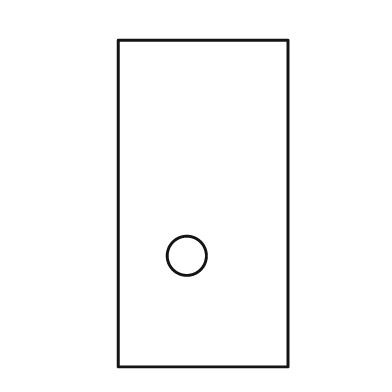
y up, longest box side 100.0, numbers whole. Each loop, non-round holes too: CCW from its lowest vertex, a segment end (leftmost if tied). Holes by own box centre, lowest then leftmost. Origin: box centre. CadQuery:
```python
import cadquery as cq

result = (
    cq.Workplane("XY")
    .moveTo(-26.0, -50.0)
    .lineTo(26.0, -50.0)
    .lineTo(26.0, 50.0)
    .lineTo(-26.0, 50.0)
    .close()
    .moveTo(-5.0, -16.0)
    .circle(6.0)
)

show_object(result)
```